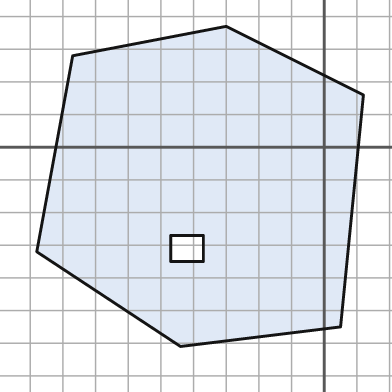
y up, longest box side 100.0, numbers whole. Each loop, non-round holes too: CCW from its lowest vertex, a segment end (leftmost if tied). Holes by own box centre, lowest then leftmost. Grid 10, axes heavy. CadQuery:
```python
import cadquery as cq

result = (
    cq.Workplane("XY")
    .moveTo(-44.0, -61.0)
    .lineTo(5.0, -55.0)
    .lineTo(12.0, 16.0)
    .lineTo(-30.0, 37.0)
    .lineTo(-77.0, 28.0)
    .lineTo(-88.0, -32.0)
    .close()
    .moveTo(-47.0, -35.0)
    .lineTo(-37.0, -35.0)
    .lineTo(-37.0, -27.0)
    .lineTo(-47.0, -27.0)
    .close()
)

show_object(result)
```